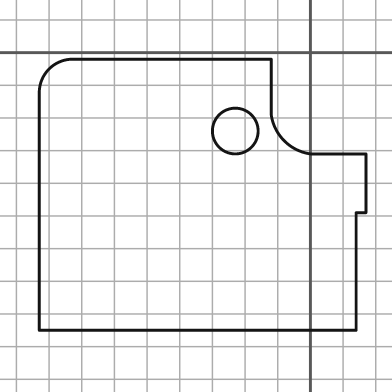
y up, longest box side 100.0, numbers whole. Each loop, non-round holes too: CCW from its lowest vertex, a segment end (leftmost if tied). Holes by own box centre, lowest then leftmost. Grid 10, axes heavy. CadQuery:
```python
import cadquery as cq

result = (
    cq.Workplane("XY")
    .moveTo(-83.0, -85.0)
    .lineTo(14.0, -85.0)
    .lineTo(14.0, -49.0)
    .lineTo(17.0, -49.0)
    .lineTo(17.0, -31.0)
    .lineTo(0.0, -31.0)
    .threePointArc((-8.0, -27.0), (-12.0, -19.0))
    .lineTo(-12.0, -2.0)
    .lineTo(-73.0, -2.0)
    .threePointArc((-80.0, -5.0), (-83.0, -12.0))
    .close()
    .moveTo(-23.0, -24.0)
    .circle(7.0)
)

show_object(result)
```